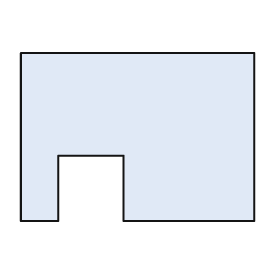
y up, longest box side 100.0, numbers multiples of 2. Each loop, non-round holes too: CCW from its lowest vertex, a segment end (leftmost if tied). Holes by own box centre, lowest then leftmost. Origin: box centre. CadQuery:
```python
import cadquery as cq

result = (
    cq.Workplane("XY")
    .moveTo(-50.0, -36.0)
    .lineTo(-34.0, -36.0)
    .lineTo(-34.0, -8.0)
    .lineTo(-6.0, -8.0)
    .lineTo(-6.0, -36.0)
    .lineTo(50.0, -36.0)
    .lineTo(50.0, 36.0)
    .lineTo(-50.0, 36.0)
    .close()
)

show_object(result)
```